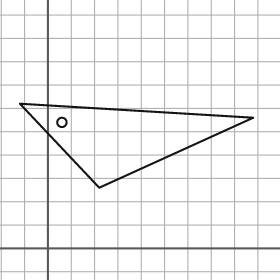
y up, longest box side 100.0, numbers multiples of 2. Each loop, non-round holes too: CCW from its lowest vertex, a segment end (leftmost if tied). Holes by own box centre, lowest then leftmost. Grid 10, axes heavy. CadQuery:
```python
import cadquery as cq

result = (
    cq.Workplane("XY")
    .moveTo(22.0, 26.0)
    .lineTo(88.0, 56.0)
    .lineTo(-12.0, 62.0)
    .close()
    .moveTo(6.0, 54.0)
    .circle(2.0)
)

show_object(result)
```